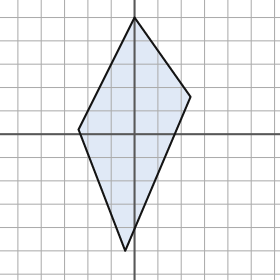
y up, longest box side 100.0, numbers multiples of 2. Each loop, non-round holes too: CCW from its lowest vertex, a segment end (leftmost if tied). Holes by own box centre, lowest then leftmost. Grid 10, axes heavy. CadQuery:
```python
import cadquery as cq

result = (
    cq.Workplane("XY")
    .moveTo(-4.0, -50.0)
    .lineTo(24.0, 16.0)
    .lineTo(0.0, 50.0)
    .lineTo(-24.0, 2.0)
    .close()
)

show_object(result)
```